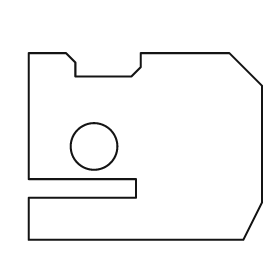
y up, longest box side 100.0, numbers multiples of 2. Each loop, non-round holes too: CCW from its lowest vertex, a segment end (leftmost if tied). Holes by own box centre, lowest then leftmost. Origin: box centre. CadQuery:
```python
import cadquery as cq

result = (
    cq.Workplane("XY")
    .moveTo(-50.0, -40.0)
    .lineTo(42.0, -40.0)
    .lineTo(50.0, -24.0)
    .lineTo(50.0, 26.0)
    .lineTo(36.0, 40.0)
    .lineTo(-2.0, 40.0)
    .lineTo(-2.0, 34.0)
    .lineTo(-6.0, 30.0)
    .lineTo(-30.0, 30.0)
    .lineTo(-30.0, 36.0)
    .lineTo(-34.0, 40.0)
    .lineTo(-50.0, 40.0)
    .lineTo(-50.0, -14.0)
    .lineTo(-4.0, -14.0)
    .lineTo(-4.0, -22.0)
    .lineTo(-50.0, -22.0)
    .close()
    .moveTo(-22.0, 0.0)
    .circle(10.0)
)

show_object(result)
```